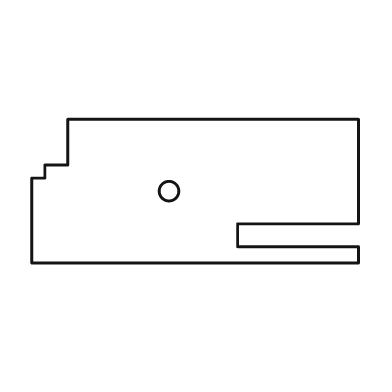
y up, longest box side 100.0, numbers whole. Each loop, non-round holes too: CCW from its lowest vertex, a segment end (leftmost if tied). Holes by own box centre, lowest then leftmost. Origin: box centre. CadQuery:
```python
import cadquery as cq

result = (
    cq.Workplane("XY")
    .moveTo(-50.0, -22.0)
    .lineTo(50.0, -22.0)
    .lineTo(50.0, -17.0)
    .lineTo(13.0, -17.0)
    .lineTo(13.0, -10.0)
    .lineTo(50.0, -10.0)
    .lineTo(50.0, 22.0)
    .lineTo(-39.0, 22.0)
    .lineTo(-39.0, 8.0)
    .lineTo(-46.0, 8.0)
    .lineTo(-46.0, 4.0)
    .lineTo(-50.0, 4.0)
    .close()
    .moveTo(-8.0, 0.0)
    .circle(3.0)
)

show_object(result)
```